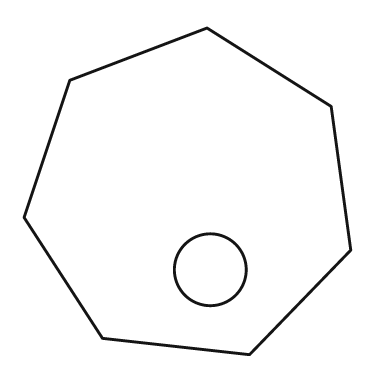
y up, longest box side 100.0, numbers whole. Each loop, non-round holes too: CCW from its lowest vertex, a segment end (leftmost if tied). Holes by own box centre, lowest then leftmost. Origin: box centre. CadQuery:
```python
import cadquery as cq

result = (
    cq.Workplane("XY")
    .moveTo(19.0, -50.0)
    .lineTo(50.0, -18.0)
    .lineTo(44.0, 26.0)
    .lineTo(6.0, 50.0)
    .lineTo(-36.0, 34.0)
    .lineTo(-50.0, -8.0)
    .lineTo(-26.0, -45.0)
    .close()
    .moveTo(7.0, -24.0)
    .circle(11.0)
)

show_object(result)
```